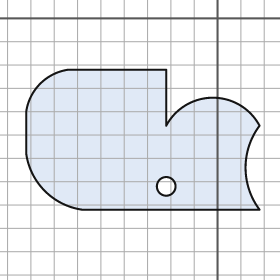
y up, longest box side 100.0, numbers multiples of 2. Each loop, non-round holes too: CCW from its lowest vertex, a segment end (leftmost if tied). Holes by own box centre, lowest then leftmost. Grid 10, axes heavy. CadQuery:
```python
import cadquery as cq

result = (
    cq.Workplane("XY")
    .moveTo(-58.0, -82.0)
    .lineTo(18.0, -82.0)
    .threePointArc((12.0, -64.0), (18.0, -46.0))
    .threePointArc((-2.0, -34.0), (-22.0, -46.0))
    .lineTo(-22.0, -22.0)
    .lineTo(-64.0, -22.0)
    .threePointArc((-76.0, -28.0), (-82.0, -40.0))
    .lineTo(-82.0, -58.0)
    .threePointArc((-74.0, -74.0), (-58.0, -82.0))
    .close()
    .moveTo(-22.0, -72.0)
    .circle(4.0)
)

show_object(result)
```